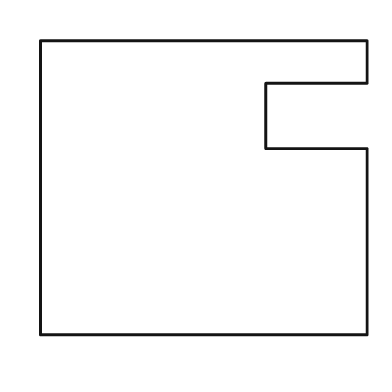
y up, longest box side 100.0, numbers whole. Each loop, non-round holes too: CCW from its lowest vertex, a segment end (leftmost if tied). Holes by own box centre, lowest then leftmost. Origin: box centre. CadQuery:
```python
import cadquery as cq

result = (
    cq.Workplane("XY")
    .moveTo(-50.0, -45.0)
    .lineTo(50.0, -45.0)
    .lineTo(50.0, 12.0)
    .lineTo(19.0, 12.0)
    .lineTo(19.0, 32.0)
    .lineTo(50.0, 32.0)
    .lineTo(50.0, 45.0)
    .lineTo(-50.0, 45.0)
    .close()
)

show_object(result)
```